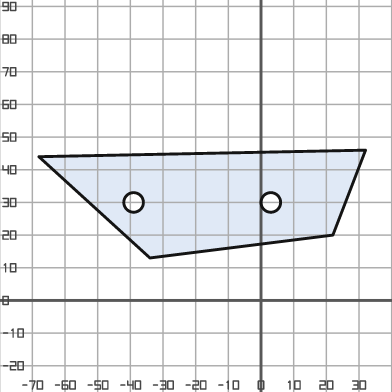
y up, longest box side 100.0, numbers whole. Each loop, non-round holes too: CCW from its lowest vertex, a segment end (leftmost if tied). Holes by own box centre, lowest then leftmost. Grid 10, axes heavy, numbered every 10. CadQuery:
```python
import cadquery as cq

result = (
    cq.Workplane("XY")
    .moveTo(-34.0, 13.0)
    .lineTo(22.0, 20.0)
    .lineTo(32.0, 46.0)
    .lineTo(-68.0, 44.0)
    .close()
    .moveTo(-39.0, 30.0)
    .circle(3.0)
    .moveTo(3.0, 30.0)
    .circle(3.0)
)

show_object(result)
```